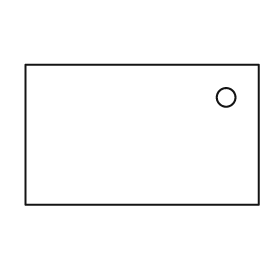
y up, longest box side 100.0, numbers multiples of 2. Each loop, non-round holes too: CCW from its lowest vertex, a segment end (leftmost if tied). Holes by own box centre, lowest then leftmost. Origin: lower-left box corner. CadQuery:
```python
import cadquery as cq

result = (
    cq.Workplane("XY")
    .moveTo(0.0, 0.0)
    .lineTo(100.0, 0.0)
    .lineTo(100.0, 60.0)
    .lineTo(0.0, 60.0)
    .close()
    .moveTo(86.0, 46.0)
    .circle(4.0)
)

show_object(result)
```